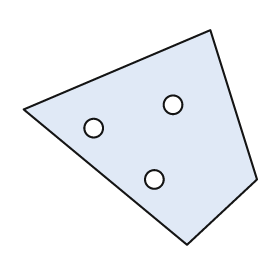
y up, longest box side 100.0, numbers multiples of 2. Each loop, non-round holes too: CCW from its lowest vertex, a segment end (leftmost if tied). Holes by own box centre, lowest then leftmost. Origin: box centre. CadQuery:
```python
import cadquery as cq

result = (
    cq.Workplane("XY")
    .moveTo(20.0, -46.0)
    .lineTo(50.0, -18.0)
    .lineTo(30.0, 46.0)
    .lineTo(-50.0, 12.0)
    .close()
    .moveTo(6.0, -18.0)
    .circle(4.0)
    .moveTo(-20.0, 4.0)
    .circle(4.0)
    .moveTo(14.0, 14.0)
    .circle(4.0)
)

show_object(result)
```